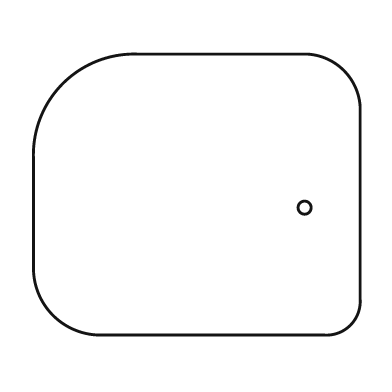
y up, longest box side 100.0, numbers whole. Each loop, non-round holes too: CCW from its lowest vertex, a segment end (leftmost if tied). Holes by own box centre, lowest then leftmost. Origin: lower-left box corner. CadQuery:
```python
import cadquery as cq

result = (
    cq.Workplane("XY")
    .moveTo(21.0, 0.0)
    .lineTo(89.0, 0.0)
    .threePointArc((97.0, 3.0), (100.0, 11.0))
    .lineTo(100.0, 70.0)
    .threePointArc((95.0, 81.0), (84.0, 86.0))
    .lineTo(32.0, 86.0)
    .threePointArc((9.0, 77.0), (0.0, 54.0))
    .lineTo(0.0, 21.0)
    .threePointArc((6.0, 6.0), (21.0, 0.0))
    .close()
    .moveTo(83.0, 39.0)
    .circle(2.0)
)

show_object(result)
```